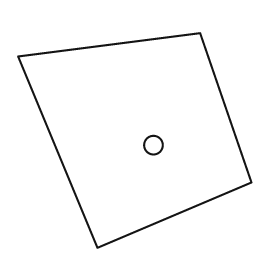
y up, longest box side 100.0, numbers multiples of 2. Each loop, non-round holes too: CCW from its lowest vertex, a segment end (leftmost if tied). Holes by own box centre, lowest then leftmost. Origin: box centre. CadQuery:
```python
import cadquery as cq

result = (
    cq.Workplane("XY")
    .moveTo(-16.0, -46.0)
    .lineTo(50.0, -18.0)
    .lineTo(28.0, 46.0)
    .lineTo(-50.0, 36.0)
    .close()
    .moveTo(8.0, -2.0)
    .circle(4.0)
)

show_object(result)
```